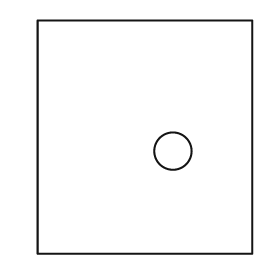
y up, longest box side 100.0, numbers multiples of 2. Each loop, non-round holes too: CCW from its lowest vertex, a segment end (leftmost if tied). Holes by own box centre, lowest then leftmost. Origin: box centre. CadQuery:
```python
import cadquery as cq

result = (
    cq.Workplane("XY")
    .moveTo(-46.0, -50.0)
    .lineTo(46.0, -50.0)
    .lineTo(46.0, 50.0)
    .lineTo(-46.0, 50.0)
    .close()
    .moveTo(12.0, -6.0)
    .circle(8.0)
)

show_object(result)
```